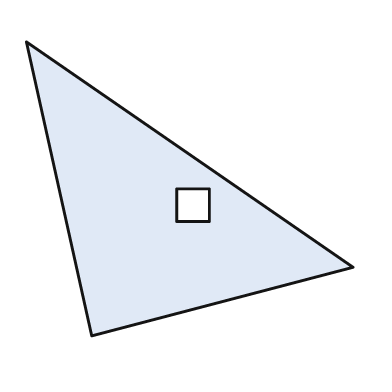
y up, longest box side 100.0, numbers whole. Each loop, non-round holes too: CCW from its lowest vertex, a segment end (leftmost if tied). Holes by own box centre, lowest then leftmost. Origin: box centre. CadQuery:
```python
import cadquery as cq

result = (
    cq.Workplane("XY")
    .moveTo(-30.0, -45.0)
    .lineTo(50.0, -24.0)
    .lineTo(-50.0, 45.0)
    .close()
    .moveTo(-4.0, -10.0)
    .lineTo(6.0, -10.0)
    .lineTo(6.0, 0.0)
    .lineTo(-4.0, 0.0)
    .close()
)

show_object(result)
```